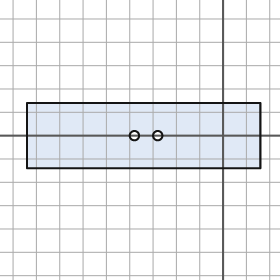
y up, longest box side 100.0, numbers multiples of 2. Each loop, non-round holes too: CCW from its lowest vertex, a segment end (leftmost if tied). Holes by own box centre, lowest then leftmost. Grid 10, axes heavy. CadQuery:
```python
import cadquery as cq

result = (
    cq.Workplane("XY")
    .moveTo(-84.0, -14.0)
    .lineTo(16.0, -14.0)
    .lineTo(16.0, 14.0)
    .lineTo(-84.0, 14.0)
    .close()
    .moveTo(-38.0, 0.0)
    .circle(2.0)
    .moveTo(-28.0, 0.0)
    .circle(2.0)
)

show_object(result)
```